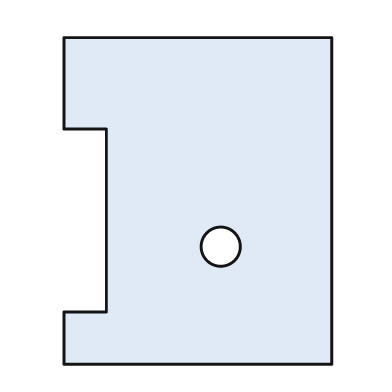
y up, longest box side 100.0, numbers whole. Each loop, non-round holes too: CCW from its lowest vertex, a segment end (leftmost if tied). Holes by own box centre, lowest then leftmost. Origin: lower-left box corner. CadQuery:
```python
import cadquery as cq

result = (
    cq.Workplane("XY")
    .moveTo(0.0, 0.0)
    .lineTo(82.0, 0.0)
    .lineTo(82.0, 100.0)
    .lineTo(0.0, 100.0)
    .lineTo(0.0, 72.0)
    .lineTo(13.0, 72.0)
    .lineTo(13.0, 16.0)
    .lineTo(0.0, 16.0)
    .close()
    .moveTo(48.0, 36.0)
    .circle(6.0)
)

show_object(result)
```